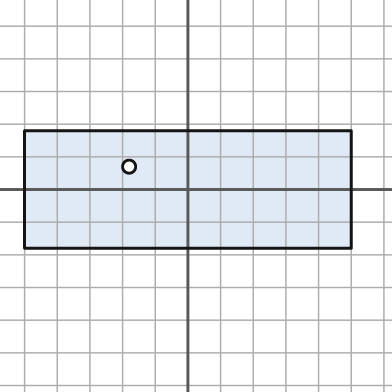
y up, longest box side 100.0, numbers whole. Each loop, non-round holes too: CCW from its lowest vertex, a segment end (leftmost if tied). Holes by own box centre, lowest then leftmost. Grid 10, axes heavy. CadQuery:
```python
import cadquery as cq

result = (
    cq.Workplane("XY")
    .moveTo(-50.0, -18.0)
    .lineTo(50.0, -18.0)
    .lineTo(50.0, 18.0)
    .lineTo(-50.0, 18.0)
    .close()
    .moveTo(-18.0, 7.0)
    .circle(2.0)
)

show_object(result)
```